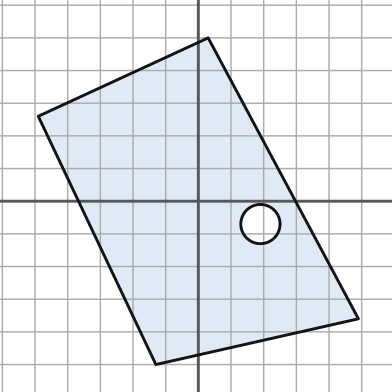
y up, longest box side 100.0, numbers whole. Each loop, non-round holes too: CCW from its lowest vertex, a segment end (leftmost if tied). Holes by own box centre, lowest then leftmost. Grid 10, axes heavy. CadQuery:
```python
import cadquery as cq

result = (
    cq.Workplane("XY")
    .moveTo(-13.0, -50.0)
    .lineTo(49.0, -36.0)
    .lineTo(3.0, 50.0)
    .lineTo(-49.0, 26.0)
    .close()
    .moveTo(19.0, -7.0)
    .circle(6.0)
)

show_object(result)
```